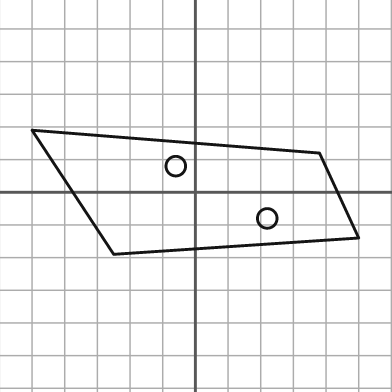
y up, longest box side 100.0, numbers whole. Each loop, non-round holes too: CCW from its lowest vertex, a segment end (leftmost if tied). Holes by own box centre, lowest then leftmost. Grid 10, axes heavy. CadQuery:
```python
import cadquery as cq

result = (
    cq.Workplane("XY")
    .moveTo(-25.0, -19.0)
    .lineTo(50.0, -14.0)
    .lineTo(38.0, 12.0)
    .lineTo(-50.0, 19.0)
    .close()
    .moveTo(22.0, -8.0)
    .circle(3.0)
    .moveTo(-6.0, 8.0)
    .circle(3.0)
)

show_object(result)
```